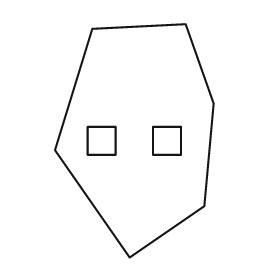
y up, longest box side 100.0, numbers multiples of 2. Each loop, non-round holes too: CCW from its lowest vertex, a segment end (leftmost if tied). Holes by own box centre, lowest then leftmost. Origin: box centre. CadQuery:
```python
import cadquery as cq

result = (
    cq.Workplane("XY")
    .moveTo(-2.0, -50.0)
    .lineTo(30.0, -28.0)
    .lineTo(34.0, 16.0)
    .lineTo(22.0, 50.0)
    .lineTo(-18.0, 48.0)
    .lineTo(-34.0, -4.0)
    .close()
    .moveTo(-20.0, -6.0)
    .lineTo(-8.0, -6.0)
    .lineTo(-8.0, 6.0)
    .lineTo(-20.0, 6.0)
    .close()
    .moveTo(8.0, -6.0)
    .lineTo(20.0, -6.0)
    .lineTo(20.0, 6.0)
    .lineTo(8.0, 6.0)
    .close()
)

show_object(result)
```